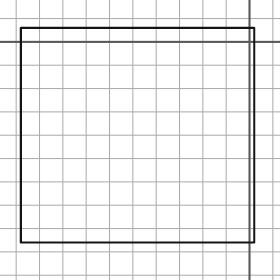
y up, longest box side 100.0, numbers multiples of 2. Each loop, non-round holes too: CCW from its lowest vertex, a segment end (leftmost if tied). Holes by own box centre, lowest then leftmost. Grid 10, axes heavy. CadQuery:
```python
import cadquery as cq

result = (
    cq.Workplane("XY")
    .moveTo(-98.0, -86.0)
    .lineTo(2.0, -86.0)
    .lineTo(2.0, 6.0)
    .lineTo(-98.0, 6.0)
    .close()
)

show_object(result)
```